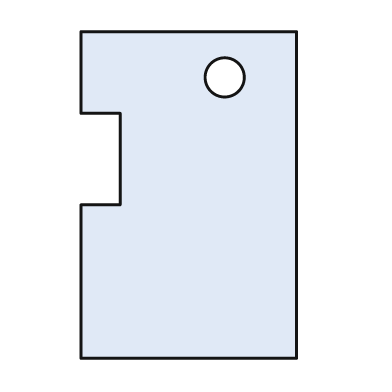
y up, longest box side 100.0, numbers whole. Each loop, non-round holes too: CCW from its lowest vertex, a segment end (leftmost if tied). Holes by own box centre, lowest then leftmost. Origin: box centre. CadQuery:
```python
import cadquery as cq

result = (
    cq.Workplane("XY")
    .moveTo(-33.0, -50.0)
    .lineTo(33.0, -50.0)
    .lineTo(33.0, 50.0)
    .lineTo(-33.0, 50.0)
    .lineTo(-33.0, 25.0)
    .lineTo(-21.0, 25.0)
    .lineTo(-21.0, -3.0)
    .lineTo(-33.0, -3.0)
    .close()
    .moveTo(11.0, 36.0)
    .circle(6.0)
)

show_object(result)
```